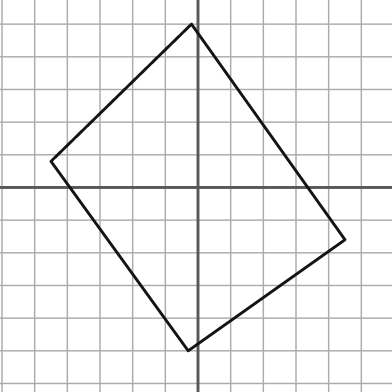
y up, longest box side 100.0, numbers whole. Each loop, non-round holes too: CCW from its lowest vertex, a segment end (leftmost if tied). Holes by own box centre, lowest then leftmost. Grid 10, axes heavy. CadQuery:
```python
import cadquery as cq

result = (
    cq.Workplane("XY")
    .moveTo(-3.0, -50.0)
    .lineTo(45.0, -16.0)
    .lineTo(-2.0, 50.0)
    .lineTo(-45.0, 8.0)
    .close()
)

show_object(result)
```